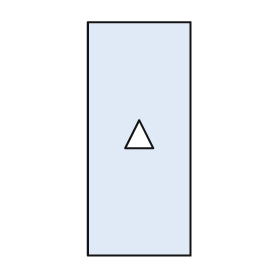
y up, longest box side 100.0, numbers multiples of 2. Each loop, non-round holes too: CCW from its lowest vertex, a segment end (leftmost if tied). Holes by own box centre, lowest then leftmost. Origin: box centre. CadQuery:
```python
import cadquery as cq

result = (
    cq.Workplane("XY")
    .moveTo(-22.0, -50.0)
    .lineTo(22.0, -50.0)
    .lineTo(22.0, 50.0)
    .lineTo(-22.0, 50.0)
    .close()
    .moveTo(-6.0, -4.0)
    .lineTo(6.0, -4.0)
    .lineTo(0.0, 8.0)
    .close()
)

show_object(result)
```